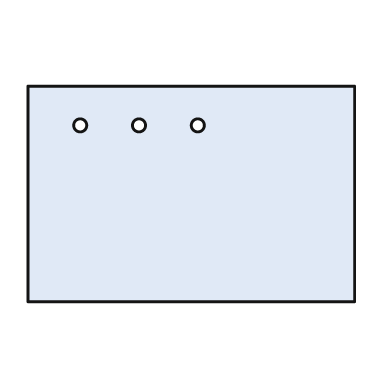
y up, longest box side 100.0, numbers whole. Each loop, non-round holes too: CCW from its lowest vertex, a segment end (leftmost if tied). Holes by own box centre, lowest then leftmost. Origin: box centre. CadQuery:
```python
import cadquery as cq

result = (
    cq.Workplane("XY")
    .moveTo(-50.0, -33.0)
    .lineTo(50.0, -33.0)
    .lineTo(50.0, 33.0)
    .lineTo(-50.0, 33.0)
    .close()
    .moveTo(-34.0, 21.0)
    .circle(2.0)
    .moveTo(-16.0, 21.0)
    .circle(2.0)
    .moveTo(2.0, 21.0)
    .circle(2.0)
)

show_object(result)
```